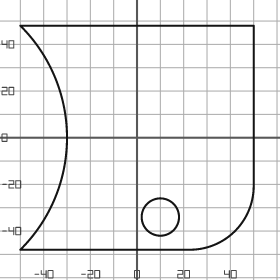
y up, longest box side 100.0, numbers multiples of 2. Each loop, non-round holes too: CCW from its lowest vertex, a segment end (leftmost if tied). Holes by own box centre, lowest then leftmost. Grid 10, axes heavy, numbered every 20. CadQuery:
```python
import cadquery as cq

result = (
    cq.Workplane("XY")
    .moveTo(-50.0, -48.0)
    .lineTo(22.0, -48.0)
    .threePointArc((42.0, -40.0), (50.0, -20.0))
    .lineTo(50.0, 48.0)
    .lineTo(-50.0, 48.0)
    .threePointArc((-30.0, 0.0), (-50.0, -48.0))
    .close()
    .moveTo(10.0, -34.0)
    .circle(8.0)
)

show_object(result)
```